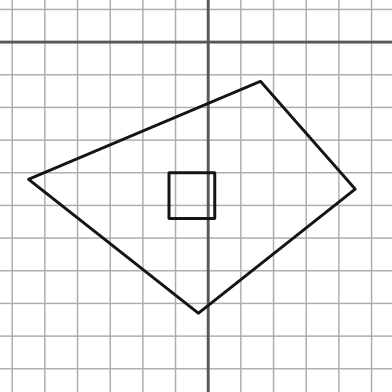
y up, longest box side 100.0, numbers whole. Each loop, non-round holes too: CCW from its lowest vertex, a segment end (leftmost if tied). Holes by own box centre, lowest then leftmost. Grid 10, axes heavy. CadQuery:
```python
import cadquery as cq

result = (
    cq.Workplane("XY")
    .moveTo(-3.0, -83.0)
    .lineTo(45.0, -45.0)
    .lineTo(16.0, -12.0)
    .lineTo(-55.0, -42.0)
    .close()
    .moveTo(-12.0, -54.0)
    .lineTo(2.0, -54.0)
    .lineTo(2.0, -40.0)
    .lineTo(-12.0, -40.0)
    .close()
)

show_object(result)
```